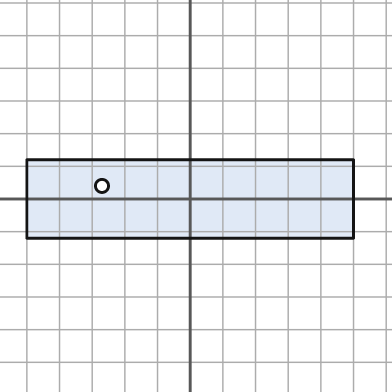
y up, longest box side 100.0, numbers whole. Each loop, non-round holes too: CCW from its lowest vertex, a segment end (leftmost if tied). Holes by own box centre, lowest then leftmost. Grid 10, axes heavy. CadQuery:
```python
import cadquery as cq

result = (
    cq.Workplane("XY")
    .moveTo(-50.0, -12.0)
    .lineTo(50.0, -12.0)
    .lineTo(50.0, 12.0)
    .lineTo(-50.0, 12.0)
    .close()
    .moveTo(-27.0, 4.0)
    .circle(2.0)
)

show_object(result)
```